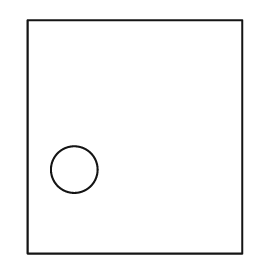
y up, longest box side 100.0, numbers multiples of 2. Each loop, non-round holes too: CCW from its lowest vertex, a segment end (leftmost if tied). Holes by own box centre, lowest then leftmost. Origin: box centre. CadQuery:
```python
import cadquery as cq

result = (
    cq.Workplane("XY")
    .moveTo(-46.0, -50.0)
    .lineTo(46.0, -50.0)
    .lineTo(46.0, 50.0)
    .lineTo(-46.0, 50.0)
    .close()
    .moveTo(-26.0, -14.0)
    .circle(10.0)
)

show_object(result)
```